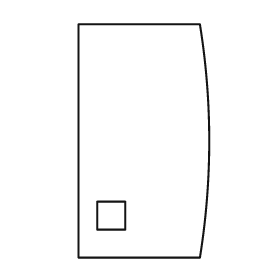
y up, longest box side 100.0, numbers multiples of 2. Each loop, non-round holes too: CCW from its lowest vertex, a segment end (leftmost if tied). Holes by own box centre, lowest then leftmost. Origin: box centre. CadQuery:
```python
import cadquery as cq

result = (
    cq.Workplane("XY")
    .moveTo(-28.0, -50.0)
    .lineTo(24.0, -50.0)
    .threePointArc((28.0, 0.0), (24.0, 50.0))
    .lineTo(-28.0, 50.0)
    .close()
    .moveTo(-20.0, -38.0)
    .lineTo(-8.0, -38.0)
    .lineTo(-8.0, -26.0)
    .lineTo(-20.0, -26.0)
    .close()
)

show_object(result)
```